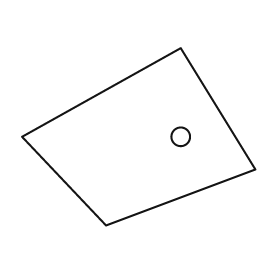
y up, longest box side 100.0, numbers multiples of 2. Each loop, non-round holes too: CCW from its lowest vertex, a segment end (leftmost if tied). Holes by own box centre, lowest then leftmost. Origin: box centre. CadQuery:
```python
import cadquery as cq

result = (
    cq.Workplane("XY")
    .moveTo(-14.0, -38.0)
    .lineTo(50.0, -14.0)
    .lineTo(18.0, 38.0)
    .lineTo(-50.0, 0.0)
    .close()
    .moveTo(18.0, 0.0)
    .circle(4.0)
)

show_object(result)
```